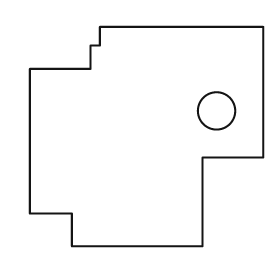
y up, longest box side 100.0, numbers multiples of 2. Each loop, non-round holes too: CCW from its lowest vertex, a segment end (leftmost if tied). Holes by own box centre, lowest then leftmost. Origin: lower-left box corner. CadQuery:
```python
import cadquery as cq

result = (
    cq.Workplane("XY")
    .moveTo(18.0, 0.0)
    .lineTo(74.0, 0.0)
    .lineTo(74.0, 38.0)
    .lineTo(100.0, 38.0)
    .lineTo(100.0, 94.0)
    .lineTo(30.0, 94.0)
    .lineTo(30.0, 86.0)
    .lineTo(26.0, 86.0)
    .lineTo(26.0, 76.0)
    .lineTo(0.0, 76.0)
    .lineTo(0.0, 14.0)
    .lineTo(18.0, 14.0)
    .close()
    .moveTo(80.0, 58.0)
    .circle(8.0)
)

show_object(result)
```